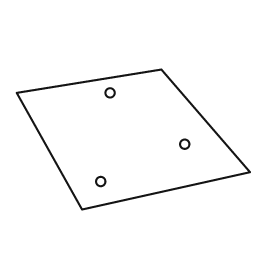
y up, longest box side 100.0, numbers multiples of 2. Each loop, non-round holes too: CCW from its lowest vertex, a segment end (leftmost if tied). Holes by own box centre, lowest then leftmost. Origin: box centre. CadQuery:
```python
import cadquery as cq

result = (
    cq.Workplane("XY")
    .moveTo(-22.0, -30.0)
    .lineTo(50.0, -14.0)
    .lineTo(12.0, 30.0)
    .lineTo(-50.0, 20.0)
    .close()
    .moveTo(-14.0, -18.0)
    .circle(2.0)
    .moveTo(22.0, -2.0)
    .circle(2.0)
    .moveTo(-10.0, 20.0)
    .circle(2.0)
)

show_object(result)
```